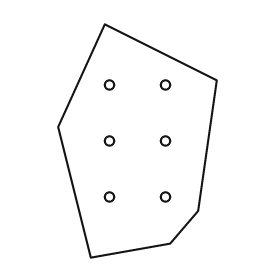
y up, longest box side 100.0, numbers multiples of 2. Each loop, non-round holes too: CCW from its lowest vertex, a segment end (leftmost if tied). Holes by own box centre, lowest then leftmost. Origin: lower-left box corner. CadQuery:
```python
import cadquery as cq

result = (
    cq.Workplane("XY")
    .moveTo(14.0, 0.0)
    .lineTo(48.0, 6.0)
    .lineTo(60.0, 20.0)
    .lineTo(68.0, 76.0)
    .lineTo(20.0, 100.0)
    .lineTo(0.0, 56.0)
    .close()
    .moveTo(22.0, 26.0)
    .circle(2.0)
    .moveTo(46.0, 26.0)
    .circle(2.0)
    .moveTo(22.0, 50.0)
    .circle(2.0)
    .moveTo(46.0, 50.0)
    .circle(2.0)
    .moveTo(22.0, 74.0)
    .circle(2.0)
    .moveTo(46.0, 74.0)
    .circle(2.0)
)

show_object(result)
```